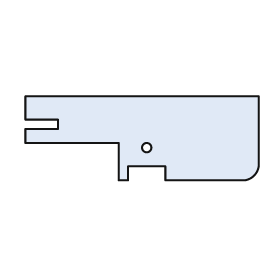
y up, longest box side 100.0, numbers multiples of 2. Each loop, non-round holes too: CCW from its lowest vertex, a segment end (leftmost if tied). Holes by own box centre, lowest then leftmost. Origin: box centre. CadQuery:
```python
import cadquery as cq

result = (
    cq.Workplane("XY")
    .moveTo(-10.0, -18.0)
    .lineTo(-6.0, -18.0)
    .lineTo(-6.0, -12.0)
    .lineTo(10.0, -12.0)
    .lineTo(10.0, -18.0)
    .lineTo(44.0, -18.0)
    .threePointArc((48.0, -16.0), (50.0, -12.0))
    .lineTo(50.0, 18.0)
    .lineTo(-50.0, 18.0)
    .lineTo(-50.0, 8.0)
    .lineTo(-36.0, 8.0)
    .lineTo(-36.0, 4.0)
    .lineTo(-50.0, 4.0)
    .lineTo(-50.0, -2.0)
    .lineTo(-10.0, -2.0)
    .close()
    .moveTo(2.0, -4.0)
    .circle(2.0)
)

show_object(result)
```